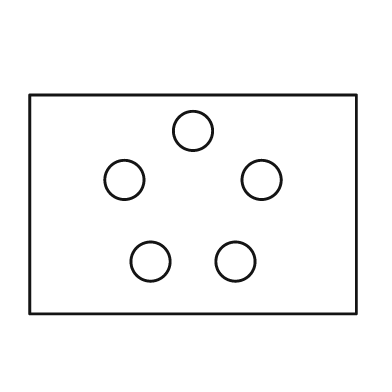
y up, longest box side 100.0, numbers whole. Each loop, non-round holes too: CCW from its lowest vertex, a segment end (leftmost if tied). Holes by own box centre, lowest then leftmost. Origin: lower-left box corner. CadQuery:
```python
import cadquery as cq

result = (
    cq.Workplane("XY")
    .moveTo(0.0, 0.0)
    .lineTo(100.0, 0.0)
    .lineTo(100.0, 67.0)
    .lineTo(0.0, 67.0)
    .close()
    .moveTo(37.0, 16.0)
    .circle(6.0)
    .moveTo(63.0, 16.0)
    .circle(6.0)
    .moveTo(29.0, 41.0)
    .circle(6.0)
    .moveTo(71.0, 41.0)
    .circle(6.0)
    .moveTo(50.0, 56.0)
    .circle(6.0)
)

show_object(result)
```